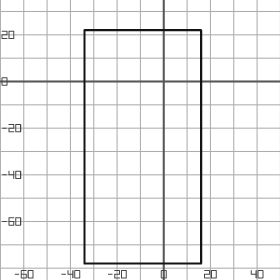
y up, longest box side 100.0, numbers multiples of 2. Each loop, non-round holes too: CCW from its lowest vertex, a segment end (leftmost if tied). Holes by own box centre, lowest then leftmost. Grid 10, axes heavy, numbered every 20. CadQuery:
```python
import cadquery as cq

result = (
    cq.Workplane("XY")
    .moveTo(-34.0, -78.0)
    .lineTo(16.0, -78.0)
    .lineTo(16.0, 22.0)
    .lineTo(-34.0, 22.0)
    .close()
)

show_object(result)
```